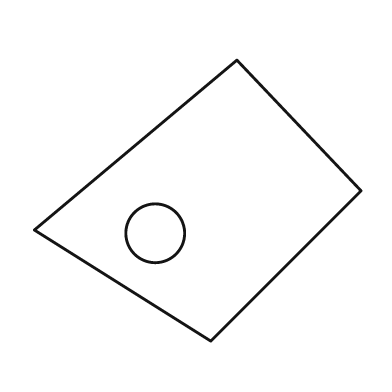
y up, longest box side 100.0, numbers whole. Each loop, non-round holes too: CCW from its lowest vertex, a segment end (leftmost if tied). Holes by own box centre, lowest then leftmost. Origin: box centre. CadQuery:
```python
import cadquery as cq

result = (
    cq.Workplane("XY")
    .moveTo(4.0, -43.0)
    .lineTo(50.0, 3.0)
    .lineTo(12.0, 43.0)
    .lineTo(-50.0, -9.0)
    .close()
    .moveTo(-13.0, -10.0)
    .circle(9.0)
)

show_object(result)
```